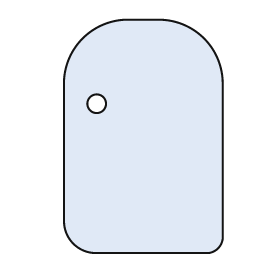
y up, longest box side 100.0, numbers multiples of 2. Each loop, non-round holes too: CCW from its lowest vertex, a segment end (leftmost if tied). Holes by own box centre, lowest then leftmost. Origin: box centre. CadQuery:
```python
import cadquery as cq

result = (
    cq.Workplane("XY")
    .moveTo(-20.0, -50.0)
    .lineTo(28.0, -50.0)
    .threePointArc((32.0, -48.0), (34.0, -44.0))
    .lineTo(34.0, 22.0)
    .threePointArc((26.0, 42.0), (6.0, 50.0))
    .lineTo(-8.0, 50.0)
    .threePointArc((-26.0, 42.0), (-34.0, 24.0))
    .lineTo(-34.0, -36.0)
    .threePointArc((-30.0, -46.0), (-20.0, -50.0))
    .close()
    .moveTo(-20.0, 14.0)
    .circle(4.0)
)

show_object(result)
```